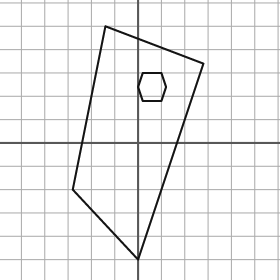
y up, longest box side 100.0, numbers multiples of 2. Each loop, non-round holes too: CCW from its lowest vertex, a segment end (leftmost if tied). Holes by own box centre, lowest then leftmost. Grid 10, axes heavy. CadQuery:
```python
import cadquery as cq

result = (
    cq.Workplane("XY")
    .moveTo(0.0, -50.0)
    .lineTo(28.0, 34.0)
    .lineTo(-14.0, 50.0)
    .lineTo(-28.0, -20.0)
    .close()
    .moveTo(2.0, 18.0)
    .lineTo(10.0, 18.0)
    .lineTo(12.0, 24.0)
    .lineTo(10.0, 30.0)
    .lineTo(2.0, 30.0)
    .lineTo(0.0, 24.0)
    .close()
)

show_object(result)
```